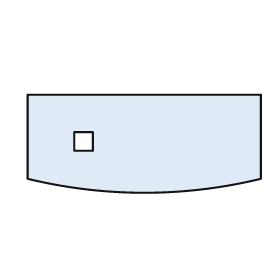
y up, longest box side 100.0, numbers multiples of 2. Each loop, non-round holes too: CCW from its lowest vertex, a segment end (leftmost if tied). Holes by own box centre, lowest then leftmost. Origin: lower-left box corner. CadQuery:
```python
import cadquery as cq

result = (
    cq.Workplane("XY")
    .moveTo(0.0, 6.0)
    .threePointArc((50.0, 0.0), (100.0, 6.0))
    .lineTo(100.0, 42.0)
    .lineTo(0.0, 42.0)
    .close()
    .moveTo(20.0, 18.0)
    .lineTo(28.0, 18.0)
    .lineTo(28.0, 26.0)
    .lineTo(20.0, 26.0)
    .close()
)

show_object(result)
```